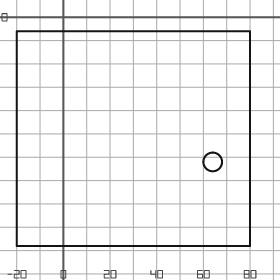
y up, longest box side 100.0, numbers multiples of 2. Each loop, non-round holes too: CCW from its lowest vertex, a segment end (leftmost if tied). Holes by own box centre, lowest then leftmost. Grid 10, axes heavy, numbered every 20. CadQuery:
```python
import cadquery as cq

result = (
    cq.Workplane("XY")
    .moveTo(-20.0, -98.0)
    .lineTo(80.0, -98.0)
    .lineTo(80.0, -6.0)
    .lineTo(-20.0, -6.0)
    .close()
    .moveTo(64.0, -62.0)
    .circle(4.0)
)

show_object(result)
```